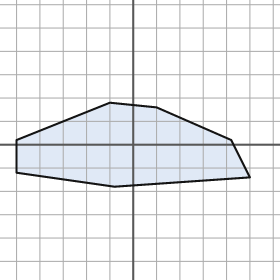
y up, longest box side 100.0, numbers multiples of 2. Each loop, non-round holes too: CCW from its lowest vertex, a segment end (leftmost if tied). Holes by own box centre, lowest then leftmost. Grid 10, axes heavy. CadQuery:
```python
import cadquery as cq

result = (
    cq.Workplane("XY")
    .moveTo(-8.0, -18.0)
    .lineTo(50.0, -14.0)
    .lineTo(42.0, 2.0)
    .lineTo(10.0, 16.0)
    .lineTo(-10.0, 18.0)
    .lineTo(-50.0, 2.0)
    .lineTo(-50.0, -12.0)
    .close()
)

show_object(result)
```